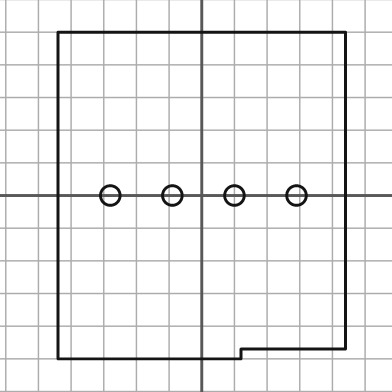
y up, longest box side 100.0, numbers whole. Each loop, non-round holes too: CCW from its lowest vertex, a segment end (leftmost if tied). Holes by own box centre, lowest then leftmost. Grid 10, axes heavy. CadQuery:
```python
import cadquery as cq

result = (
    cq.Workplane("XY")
    .moveTo(-44.0, -50.0)
    .lineTo(12.0, -50.0)
    .lineTo(12.0, -47.0)
    .lineTo(44.0, -47.0)
    .lineTo(44.0, 50.0)
    .lineTo(-44.0, 50.0)
    .close()
    .moveTo(-28.0, 0.0)
    .circle(3.0)
    .moveTo(-9.0, 0.0)
    .circle(3.0)
    .moveTo(10.0, 0.0)
    .circle(3.0)
    .moveTo(29.0, 0.0)
    .circle(3.0)
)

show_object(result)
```